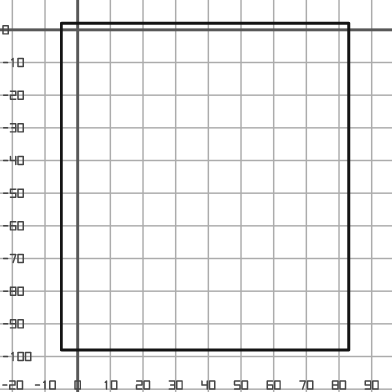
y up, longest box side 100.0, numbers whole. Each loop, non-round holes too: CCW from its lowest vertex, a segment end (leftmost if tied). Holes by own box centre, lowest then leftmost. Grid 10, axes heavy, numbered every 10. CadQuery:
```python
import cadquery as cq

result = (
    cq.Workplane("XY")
    .moveTo(-5.0, -98.0)
    .lineTo(83.0, -98.0)
    .lineTo(83.0, 2.0)
    .lineTo(-5.0, 2.0)
    .close()
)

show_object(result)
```